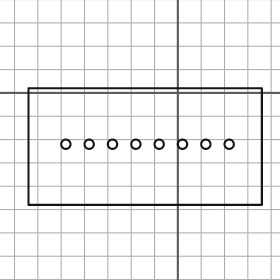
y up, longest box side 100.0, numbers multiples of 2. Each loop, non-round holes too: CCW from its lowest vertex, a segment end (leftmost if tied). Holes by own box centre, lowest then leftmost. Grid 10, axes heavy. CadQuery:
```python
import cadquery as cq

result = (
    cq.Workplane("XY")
    .moveTo(-64.0, -48.0)
    .lineTo(36.0, -48.0)
    .lineTo(36.0, 2.0)
    .lineTo(-64.0, 2.0)
    .close()
    .moveTo(-48.0, -22.0)
    .circle(2.0)
    .moveTo(-38.0, -22.0)
    .circle(2.0)
    .moveTo(-28.0, -22.0)
    .circle(2.0)
    .moveTo(-18.0, -22.0)
    .circle(2.0)
    .moveTo(-8.0, -22.0)
    .circle(2.0)
    .moveTo(2.0, -22.0)
    .circle(2.0)
    .moveTo(12.0, -22.0)
    .circle(2.0)
    .moveTo(22.0, -22.0)
    .circle(2.0)
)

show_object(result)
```